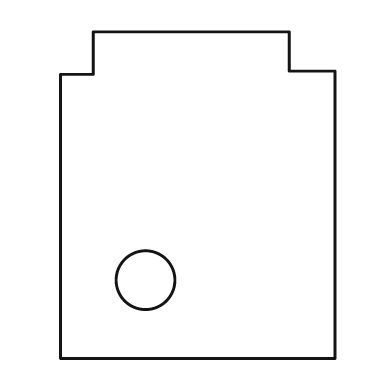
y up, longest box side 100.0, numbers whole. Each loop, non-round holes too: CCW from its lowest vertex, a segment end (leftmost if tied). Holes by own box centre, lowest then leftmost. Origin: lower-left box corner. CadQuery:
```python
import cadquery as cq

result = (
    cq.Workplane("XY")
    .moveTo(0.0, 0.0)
    .lineTo(84.0, 0.0)
    .lineTo(84.0, 88.0)
    .lineTo(70.0, 88.0)
    .lineTo(70.0, 100.0)
    .lineTo(10.0, 100.0)
    .lineTo(10.0, 87.0)
    .lineTo(0.0, 87.0)
    .close()
    .moveTo(26.0, 24.0)
    .circle(9.0)
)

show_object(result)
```